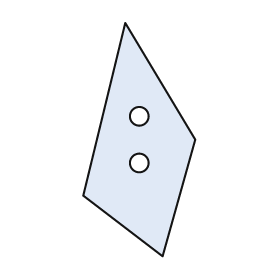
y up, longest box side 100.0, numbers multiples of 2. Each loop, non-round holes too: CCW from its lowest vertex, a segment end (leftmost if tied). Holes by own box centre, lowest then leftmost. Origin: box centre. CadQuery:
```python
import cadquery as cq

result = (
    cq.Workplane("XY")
    .moveTo(10.0, -50.0)
    .lineTo(24.0, 0.0)
    .lineTo(-6.0, 50.0)
    .lineTo(-24.0, -24.0)
    .close()
    .moveTo(0.0, -10.0)
    .circle(4.0)
    .moveTo(0.0, 10.0)
    .circle(4.0)
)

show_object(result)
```